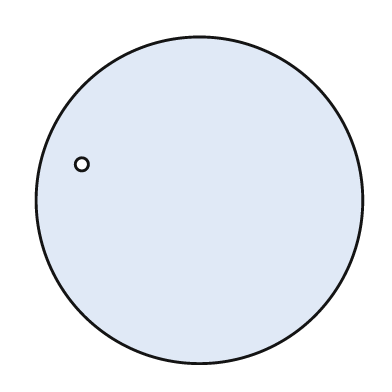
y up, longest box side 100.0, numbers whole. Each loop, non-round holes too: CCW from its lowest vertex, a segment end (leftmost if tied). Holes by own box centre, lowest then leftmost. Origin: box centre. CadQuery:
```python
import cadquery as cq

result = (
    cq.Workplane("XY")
    .moveTo(0.0, 0.0)
    .circle(50.0)
    .moveTo(-36.0, 11.0)
    .circle(2.0)
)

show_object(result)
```